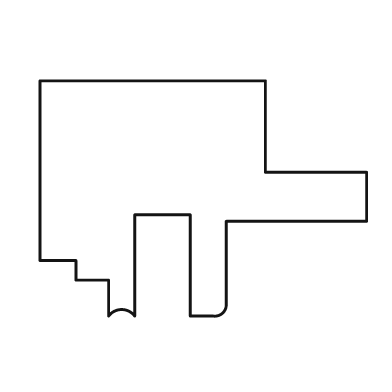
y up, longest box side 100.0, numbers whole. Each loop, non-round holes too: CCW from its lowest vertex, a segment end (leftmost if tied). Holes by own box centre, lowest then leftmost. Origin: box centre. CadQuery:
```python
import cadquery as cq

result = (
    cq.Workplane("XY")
    .moveTo(-29.0, -36.0)
    .threePointArc((-25.0, -34.0), (-21.0, -36.0))
    .lineTo(-21.0, -5.0)
    .lineTo(-4.0, -5.0)
    .lineTo(-4.0, -36.0)
    .lineTo(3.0, -36.0)
    .threePointArc((6.0, -35.0), (7.0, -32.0))
    .lineTo(7.0, -7.0)
    .lineTo(50.0, -7.0)
    .lineTo(50.0, 8.0)
    .lineTo(19.0, 8.0)
    .lineTo(19.0, 36.0)
    .lineTo(-50.0, 36.0)
    .lineTo(-50.0, -19.0)
    .lineTo(-39.0, -19.0)
    .lineTo(-39.0, -25.0)
    .lineTo(-29.0, -25.0)
    .close()
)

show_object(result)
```